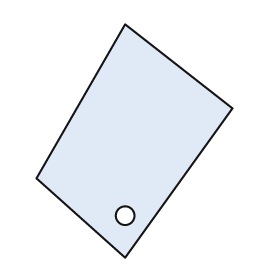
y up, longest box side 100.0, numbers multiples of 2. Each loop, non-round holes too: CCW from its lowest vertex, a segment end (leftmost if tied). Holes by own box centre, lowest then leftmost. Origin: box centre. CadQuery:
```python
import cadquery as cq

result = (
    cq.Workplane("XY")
    .moveTo(-4.0, -50.0)
    .lineTo(42.0, 14.0)
    .lineTo(-4.0, 50.0)
    .lineTo(-42.0, -16.0)
    .close()
    .moveTo(-4.0, -32.0)
    .circle(4.0)
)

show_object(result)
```